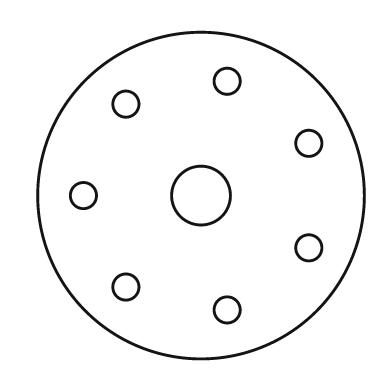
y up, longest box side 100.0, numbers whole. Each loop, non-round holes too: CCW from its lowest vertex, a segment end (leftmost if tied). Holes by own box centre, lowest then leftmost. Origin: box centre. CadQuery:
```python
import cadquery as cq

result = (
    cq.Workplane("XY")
    .moveTo(0.0, 0.0)
    .circle(50.0)
    .moveTo(8.0, -35.0)
    .circle(4.0)
    .moveTo(-23.0, -28.0)
    .circle(4.0)
    .moveTo(33.0, -16.0)
    .circle(4.0)
    .moveTo(-36.0, 0.0)
    .circle(4.0)
    .moveTo(0.0, 0.0)
    .circle(9.0)
    .moveTo(33.0, 16.0)
    .circle(4.0)
    .moveTo(-23.0, 28.0)
    .circle(4.0)
    .moveTo(8.0, 35.0)
    .circle(4.0)
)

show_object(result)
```